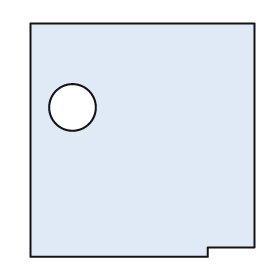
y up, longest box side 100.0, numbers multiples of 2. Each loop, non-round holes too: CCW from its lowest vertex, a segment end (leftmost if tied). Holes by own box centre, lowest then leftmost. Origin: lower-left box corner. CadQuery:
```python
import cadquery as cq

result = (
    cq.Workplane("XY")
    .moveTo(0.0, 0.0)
    .lineTo(76.0, 0.0)
    .lineTo(76.0, 4.0)
    .lineTo(96.0, 4.0)
    .lineTo(96.0, 100.0)
    .lineTo(0.0, 100.0)
    .close()
    .moveTo(18.0, 64.0)
    .circle(10.0)
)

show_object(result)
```